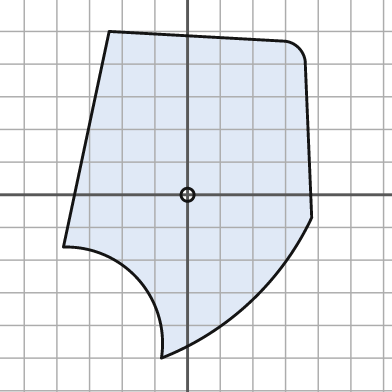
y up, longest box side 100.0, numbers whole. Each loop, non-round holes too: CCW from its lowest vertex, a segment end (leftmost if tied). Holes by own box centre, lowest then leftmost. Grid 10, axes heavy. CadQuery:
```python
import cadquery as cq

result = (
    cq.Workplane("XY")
    .moveTo(-8.0, -50.0)
    .threePointArc((19.0, -33.0), (38.0, -7.0))
    .lineTo(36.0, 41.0)
    .threePointArc((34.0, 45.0), (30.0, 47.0))
    .lineTo(-24.0, 50.0)
    .lineTo(-38.0, -16.0)
    .threePointArc((-15.0, -26.0), (-8.0, -50.0))
    .close()
    .moveTo(0.0, 0.0)
    .circle(2.0)
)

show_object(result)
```